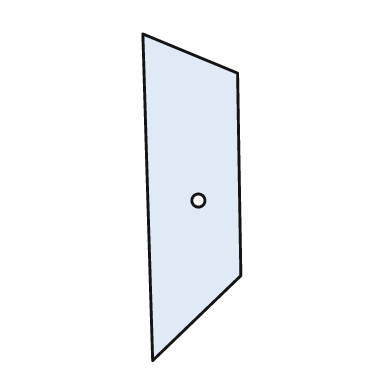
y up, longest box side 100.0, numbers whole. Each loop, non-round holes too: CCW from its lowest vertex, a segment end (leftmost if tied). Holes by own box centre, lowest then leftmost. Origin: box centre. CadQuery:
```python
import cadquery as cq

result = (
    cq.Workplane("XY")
    .moveTo(-12.0, -50.0)
    .lineTo(15.0, -24.0)
    .lineTo(14.0, 38.0)
    .lineTo(-15.0, 50.0)
    .close()
    .moveTo(2.0, -1.0)
    .circle(2.0)
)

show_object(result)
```